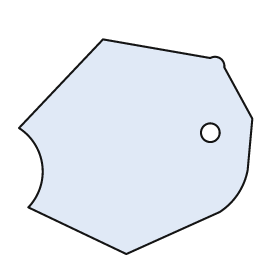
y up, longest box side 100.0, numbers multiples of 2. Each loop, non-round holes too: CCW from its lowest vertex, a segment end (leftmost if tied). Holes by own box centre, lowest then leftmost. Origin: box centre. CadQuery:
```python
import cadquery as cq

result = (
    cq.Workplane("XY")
    .moveTo(-4.0, -46.0)
    .lineTo(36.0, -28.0)
    .threePointArc((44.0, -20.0), (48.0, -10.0))
    .lineTo(50.0, 12.0)
    .lineTo(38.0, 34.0)
    .threePointArc((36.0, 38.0), (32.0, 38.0))
    .lineTo(-14.0, 46.0)
    .lineTo(-50.0, 8.0)
    .threePointArc((-40.0, -8.0), (-46.0, -26.0))
    .close()
    .moveTo(32.0, 6.0)
    .circle(4.0)
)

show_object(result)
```